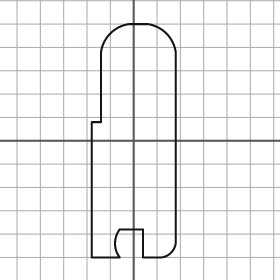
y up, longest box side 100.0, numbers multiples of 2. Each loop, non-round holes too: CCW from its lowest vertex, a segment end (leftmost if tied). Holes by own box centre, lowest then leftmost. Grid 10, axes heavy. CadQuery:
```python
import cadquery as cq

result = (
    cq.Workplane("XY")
    .moveTo(-18.0, -50.0)
    .lineTo(-6.0, -50.0)
    .threePointArc((-8.0, -44.0), (-6.0, -38.0))
    .lineTo(4.0, -38.0)
    .lineTo(4.0, -50.0)
    .lineTo(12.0, -50.0)
    .threePointArc((16.0, -48.0), (18.0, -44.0))
    .lineTo(18.0, 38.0)
    .threePointArc((14.0, 46.0), (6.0, 50.0))
    .lineTo(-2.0, 50.0)
    .threePointArc((-10.0, 46.0), (-14.0, 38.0))
    .lineTo(-14.0, 8.0)
    .lineTo(-18.0, 8.0)
    .close()
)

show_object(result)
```